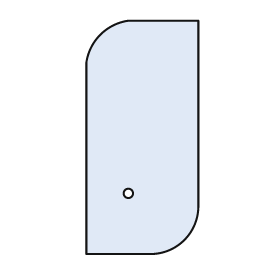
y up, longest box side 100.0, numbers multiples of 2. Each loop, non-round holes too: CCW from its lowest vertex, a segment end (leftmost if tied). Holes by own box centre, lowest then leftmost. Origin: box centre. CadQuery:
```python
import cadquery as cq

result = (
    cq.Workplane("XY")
    .moveTo(-24.0, -50.0)
    .lineTo(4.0, -50.0)
    .threePointArc((18.0, -44.0), (24.0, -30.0))
    .lineTo(24.0, 50.0)
    .lineTo(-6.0, 50.0)
    .threePointArc((-18.0, 44.0), (-24.0, 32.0))
    .close()
    .moveTo(-6.0, -24.0)
    .circle(2.0)
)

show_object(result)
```